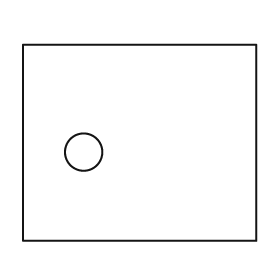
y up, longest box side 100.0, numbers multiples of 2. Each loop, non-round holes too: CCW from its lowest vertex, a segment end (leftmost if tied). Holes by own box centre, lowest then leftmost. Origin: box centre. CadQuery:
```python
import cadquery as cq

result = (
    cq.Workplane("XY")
    .moveTo(-50.0, -42.0)
    .lineTo(50.0, -42.0)
    .lineTo(50.0, 42.0)
    .lineTo(-50.0, 42.0)
    .close()
    .moveTo(-24.0, -4.0)
    .circle(8.0)
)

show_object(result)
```